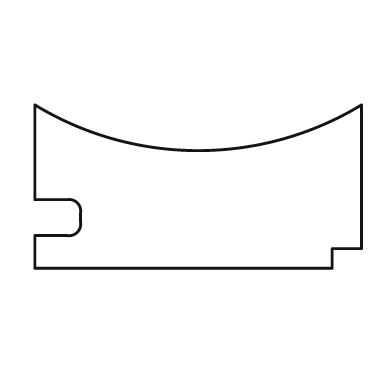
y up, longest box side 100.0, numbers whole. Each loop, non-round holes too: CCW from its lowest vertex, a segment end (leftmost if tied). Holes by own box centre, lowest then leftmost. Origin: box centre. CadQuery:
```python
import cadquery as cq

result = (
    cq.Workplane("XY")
    .moveTo(-50.0, -25.0)
    .lineTo(41.0, -25.0)
    .lineTo(41.0, -19.0)
    .lineTo(50.0, -19.0)
    .lineTo(50.0, 25.0)
    .threePointArc((0.0, 11.0), (-50.0, 25.0))
    .lineTo(-50.0, -4.0)
    .lineTo(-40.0, -4.0)
    .threePointArc((-37.0, -5.0), (-36.0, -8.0))
    .lineTo(-36.0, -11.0)
    .threePointArc((-37.0, -14.0), (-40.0, -15.0))
    .lineTo(-50.0, -15.0)
    .close()
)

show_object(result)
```